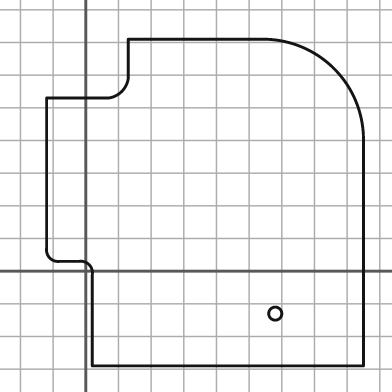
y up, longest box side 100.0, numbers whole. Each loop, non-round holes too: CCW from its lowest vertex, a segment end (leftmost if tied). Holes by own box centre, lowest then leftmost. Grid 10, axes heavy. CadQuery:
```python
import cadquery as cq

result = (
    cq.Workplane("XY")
    .moveTo(2.0, -29.0)
    .lineTo(85.0, -29.0)
    .lineTo(85.0, 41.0)
    .threePointArc((76.0, 62.0), (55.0, 71.0))
    .lineTo(13.0, 71.0)
    .lineTo(13.0, 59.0)
    .threePointArc((11.0, 55.0), (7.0, 53.0))
    .lineTo(-12.0, 53.0)
    .lineTo(-12.0, 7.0)
    .threePointArc((-11.0, 4.0), (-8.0, 3.0))
    .lineTo(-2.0, 3.0)
    .threePointArc((1.0, 2.0), (2.0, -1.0))
    .close()
    .moveTo(58.0, -13.0)
    .circle(2.0)
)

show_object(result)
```